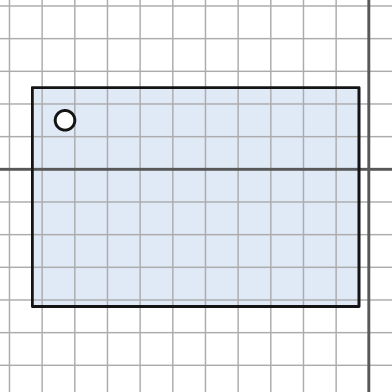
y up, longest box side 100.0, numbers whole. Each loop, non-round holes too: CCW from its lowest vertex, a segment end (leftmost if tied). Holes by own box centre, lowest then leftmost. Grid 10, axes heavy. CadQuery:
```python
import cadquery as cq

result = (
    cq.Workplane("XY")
    .moveTo(-103.0, -42.0)
    .lineTo(-3.0, -42.0)
    .lineTo(-3.0, 25.0)
    .lineTo(-103.0, 25.0)
    .close()
    .moveTo(-93.0, 15.0)
    .circle(3.0)
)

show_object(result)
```